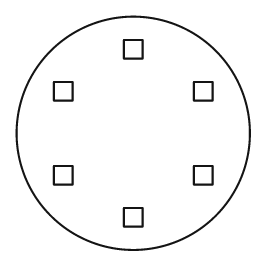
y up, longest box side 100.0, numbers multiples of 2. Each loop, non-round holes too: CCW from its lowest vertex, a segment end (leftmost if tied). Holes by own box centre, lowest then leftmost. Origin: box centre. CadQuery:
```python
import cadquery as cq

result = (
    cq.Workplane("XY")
    .moveTo(0.0, 0.0)
    .circle(50.0)
    .moveTo(-4.0, -40.0)
    .lineTo(4.0, -40.0)
    .lineTo(4.0, -32.0)
    .lineTo(-4.0, -32.0)
    .close()
    .moveTo(-34.0, -22.0)
    .lineTo(-26.0, -22.0)
    .lineTo(-26.0, -14.0)
    .lineTo(-34.0, -14.0)
    .close()
    .moveTo(26.0, -22.0)
    .lineTo(34.0, -22.0)
    .lineTo(34.0, -14.0)
    .lineTo(26.0, -14.0)
    .close()
    .moveTo(-34.0, 14.0)
    .lineTo(-26.0, 14.0)
    .lineTo(-26.0, 22.0)
    .lineTo(-34.0, 22.0)
    .close()
    .moveTo(26.0, 14.0)
    .lineTo(34.0, 14.0)
    .lineTo(34.0, 22.0)
    .lineTo(26.0, 22.0)
    .close()
    .moveTo(-4.0, 32.0)
    .lineTo(4.0, 32.0)
    .lineTo(4.0, 40.0)
    .lineTo(-4.0, 40.0)
    .close()
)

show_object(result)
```